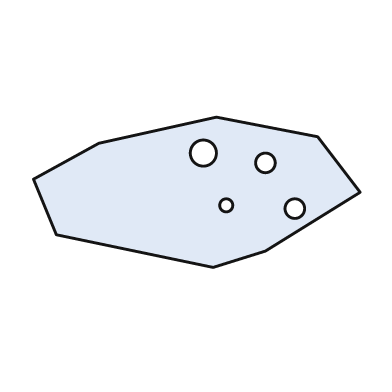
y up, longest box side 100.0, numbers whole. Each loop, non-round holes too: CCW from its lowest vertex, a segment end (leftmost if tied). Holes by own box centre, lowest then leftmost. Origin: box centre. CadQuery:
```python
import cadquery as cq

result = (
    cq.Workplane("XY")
    .moveTo(5.0, -23.0)
    .lineTo(21.0, -18.0)
    .lineTo(50.0, 0.0)
    .lineTo(37.0, 17.0)
    .lineTo(6.0, 23.0)
    .lineTo(-30.0, 15.0)
    .lineTo(-50.0, 4.0)
    .lineTo(-43.0, -13.0)
    .close()
    .moveTo(30.0, -5.0)
    .circle(3.0)
    .moveTo(9.0, -4.0)
    .circle(2.0)
    .moveTo(21.0, 9.0)
    .circle(3.0)
    .moveTo(2.0, 12.0)
    .circle(4.0)
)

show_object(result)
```